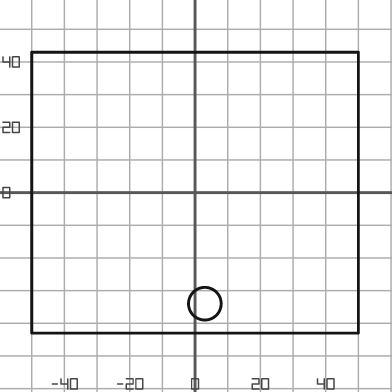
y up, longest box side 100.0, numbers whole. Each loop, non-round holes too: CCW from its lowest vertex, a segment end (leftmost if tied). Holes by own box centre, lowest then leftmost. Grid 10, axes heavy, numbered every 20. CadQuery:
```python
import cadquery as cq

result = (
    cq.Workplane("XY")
    .moveTo(-50.0, -43.0)
    .lineTo(50.0, -43.0)
    .lineTo(50.0, 43.0)
    .lineTo(-50.0, 43.0)
    .close()
    .moveTo(3.0, -34.0)
    .circle(5.0)
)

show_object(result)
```